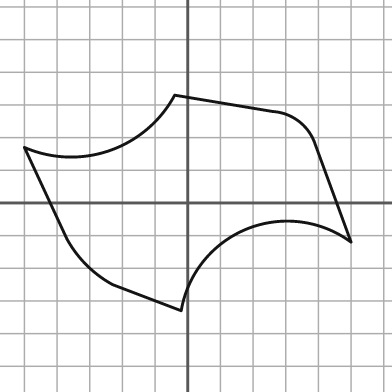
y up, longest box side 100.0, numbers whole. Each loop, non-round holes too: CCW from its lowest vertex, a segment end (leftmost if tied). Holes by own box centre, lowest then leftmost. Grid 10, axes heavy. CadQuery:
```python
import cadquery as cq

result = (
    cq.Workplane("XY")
    .moveTo(-2.0, -33.0)
    .threePointArc((18.0, -8.0), (50.0, -12.0))
    .lineTo(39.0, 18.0)
    .threePointArc((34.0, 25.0), (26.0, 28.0))
    .lineTo(-4.0, 33.0)
    .threePointArc((-24.0, 16.0), (-50.0, 17.0))
    .lineTo(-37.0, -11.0)
    .threePointArc((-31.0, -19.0), (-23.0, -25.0))
    .close()
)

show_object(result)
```